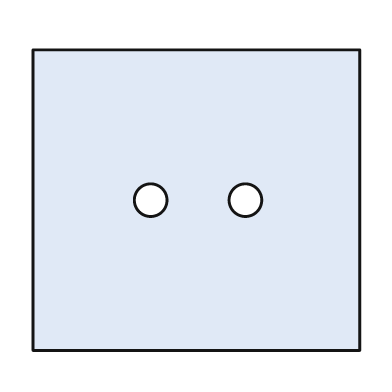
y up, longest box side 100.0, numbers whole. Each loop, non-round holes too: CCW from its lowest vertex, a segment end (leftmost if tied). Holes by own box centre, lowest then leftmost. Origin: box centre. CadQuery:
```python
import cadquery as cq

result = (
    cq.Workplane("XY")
    .moveTo(-50.0, -46.0)
    .lineTo(50.0, -46.0)
    .lineTo(50.0, 46.0)
    .lineTo(-50.0, 46.0)
    .close()
    .moveTo(-14.0, 0.0)
    .circle(5.0)
    .moveTo(15.0, 0.0)
    .circle(5.0)
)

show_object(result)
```